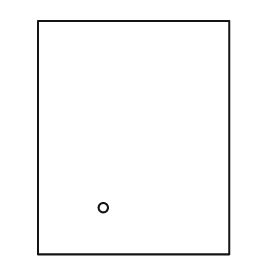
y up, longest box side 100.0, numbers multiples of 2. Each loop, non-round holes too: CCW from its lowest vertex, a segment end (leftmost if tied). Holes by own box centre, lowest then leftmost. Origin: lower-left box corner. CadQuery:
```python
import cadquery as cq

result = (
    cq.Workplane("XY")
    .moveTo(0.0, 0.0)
    .lineTo(82.0, 0.0)
    .lineTo(82.0, 100.0)
    .lineTo(0.0, 100.0)
    .close()
    .moveTo(28.0, 20.0)
    .circle(2.0)
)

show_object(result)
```